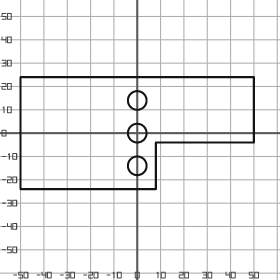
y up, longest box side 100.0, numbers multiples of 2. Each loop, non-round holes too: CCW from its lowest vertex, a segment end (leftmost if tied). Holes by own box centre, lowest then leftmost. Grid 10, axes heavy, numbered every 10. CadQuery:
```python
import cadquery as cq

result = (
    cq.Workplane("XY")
    .moveTo(-50.0, -24.0)
    .lineTo(8.0, -24.0)
    .lineTo(8.0, -4.0)
    .lineTo(50.0, -4.0)
    .lineTo(50.0, 24.0)
    .lineTo(-50.0, 24.0)
    .close()
    .moveTo(0.0, -14.0)
    .circle(4.0)
    .moveTo(0.0, 0.0)
    .circle(4.0)
    .moveTo(0.0, 14.0)
    .circle(4.0)
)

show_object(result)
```